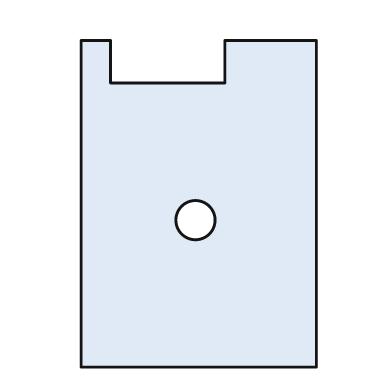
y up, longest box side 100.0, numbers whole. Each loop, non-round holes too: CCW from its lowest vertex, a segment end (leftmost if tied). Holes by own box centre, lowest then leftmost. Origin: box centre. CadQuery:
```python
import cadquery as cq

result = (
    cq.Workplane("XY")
    .moveTo(-36.0, -50.0)
    .lineTo(36.0, -50.0)
    .lineTo(36.0, 50.0)
    .lineTo(8.0, 50.0)
    .lineTo(8.0, 37.0)
    .lineTo(-27.0, 37.0)
    .lineTo(-27.0, 50.0)
    .lineTo(-36.0, 50.0)
    .close()
    .moveTo(-1.0, -5.0)
    .circle(6.0)
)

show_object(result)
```